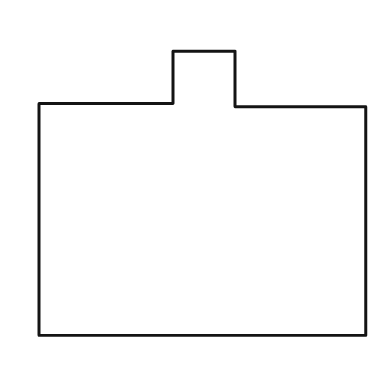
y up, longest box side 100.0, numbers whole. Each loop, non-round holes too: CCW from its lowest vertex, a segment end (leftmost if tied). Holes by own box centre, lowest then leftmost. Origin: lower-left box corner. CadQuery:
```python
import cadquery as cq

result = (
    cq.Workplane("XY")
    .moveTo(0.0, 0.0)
    .lineTo(100.0, 0.0)
    .lineTo(100.0, 70.0)
    .lineTo(60.0, 70.0)
    .lineTo(60.0, 87.0)
    .lineTo(41.0, 87.0)
    .lineTo(41.0, 71.0)
    .lineTo(0.0, 71.0)
    .close()
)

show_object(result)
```